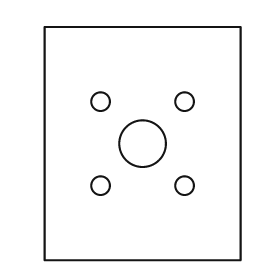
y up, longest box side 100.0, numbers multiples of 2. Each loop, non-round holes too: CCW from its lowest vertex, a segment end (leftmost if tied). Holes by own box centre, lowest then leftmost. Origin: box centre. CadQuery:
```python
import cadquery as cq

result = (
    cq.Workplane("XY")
    .moveTo(-42.0, -50.0)
    .lineTo(42.0, -50.0)
    .lineTo(42.0, 50.0)
    .lineTo(-42.0, 50.0)
    .close()
    .moveTo(-18.0, -18.0)
    .circle(4.0)
    .moveTo(18.0, -18.0)
    .circle(4.0)
    .moveTo(0.0, 0.0)
    .circle(10.0)
    .moveTo(-18.0, 18.0)
    .circle(4.0)
    .moveTo(18.0, 18.0)
    .circle(4.0)
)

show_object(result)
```